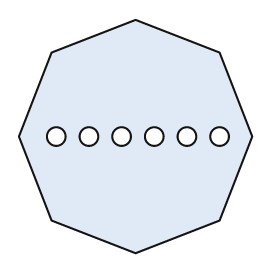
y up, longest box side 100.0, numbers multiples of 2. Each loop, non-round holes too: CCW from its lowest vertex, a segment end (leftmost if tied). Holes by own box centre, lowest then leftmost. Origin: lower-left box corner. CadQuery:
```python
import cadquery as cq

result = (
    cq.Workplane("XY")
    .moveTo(50.0, 0.0)
    .lineTo(86.0, 14.0)
    .lineTo(100.0, 50.0)
    .lineTo(86.0, 86.0)
    .lineTo(50.0, 100.0)
    .lineTo(14.0, 86.0)
    .lineTo(0.0, 50.0)
    .lineTo(14.0, 14.0)
    .close()
    .moveTo(16.0, 50.0)
    .circle(4.0)
    .moveTo(30.0, 50.0)
    .circle(4.0)
    .moveTo(44.0, 50.0)
    .circle(4.0)
    .moveTo(58.0, 50.0)
    .circle(4.0)
    .moveTo(72.0, 50.0)
    .circle(4.0)
    .moveTo(86.0, 50.0)
    .circle(4.0)
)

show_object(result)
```